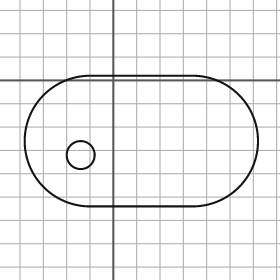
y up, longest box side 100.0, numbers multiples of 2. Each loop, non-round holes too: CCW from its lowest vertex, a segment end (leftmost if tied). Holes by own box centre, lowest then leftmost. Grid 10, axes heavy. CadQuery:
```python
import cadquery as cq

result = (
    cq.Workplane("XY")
    .moveTo(-10.0, -54.0)
    .lineTo(34.0, -54.0)
    .threePointArc((62.0, -26.0), (34.0, 2.0))
    .lineTo(-10.0, 2.0)
    .threePointArc((-38.0, -26.0), (-10.0, -54.0))
    .close()
    .moveTo(-14.0, -32.0)
    .circle(6.0)
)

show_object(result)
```